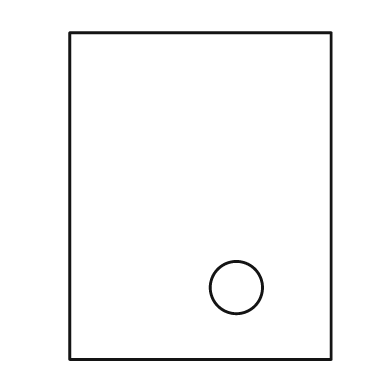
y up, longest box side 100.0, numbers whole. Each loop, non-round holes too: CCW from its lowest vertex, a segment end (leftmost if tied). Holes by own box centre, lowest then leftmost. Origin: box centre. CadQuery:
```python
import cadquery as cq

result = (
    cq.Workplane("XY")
    .moveTo(-40.0, -50.0)
    .lineTo(40.0, -50.0)
    .lineTo(40.0, 50.0)
    .lineTo(-40.0, 50.0)
    .close()
    .moveTo(11.0, -28.0)
    .circle(8.0)
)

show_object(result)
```